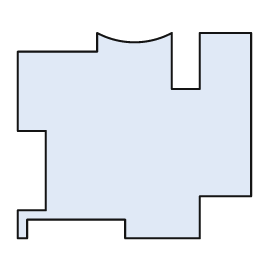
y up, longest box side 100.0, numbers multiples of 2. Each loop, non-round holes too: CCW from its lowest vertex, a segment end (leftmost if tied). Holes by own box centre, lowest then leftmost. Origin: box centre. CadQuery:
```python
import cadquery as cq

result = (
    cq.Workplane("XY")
    .moveTo(-50.0, -44.0)
    .lineTo(-46.0, -44.0)
    .lineTo(-46.0, -36.0)
    .lineTo(-4.0, -36.0)
    .lineTo(-4.0, -44.0)
    .lineTo(28.0, -44.0)
    .lineTo(28.0, -26.0)
    .lineTo(50.0, -26.0)
    .lineTo(50.0, 44.0)
    .lineTo(28.0, 44.0)
    .lineTo(28.0, 20.0)
    .lineTo(16.0, 20.0)
    .lineTo(16.0, 44.0)
    .threePointArc((0.0, 40.0), (-16.0, 44.0))
    .lineTo(-16.0, 36.0)
    .lineTo(-50.0, 36.0)
    .lineTo(-50.0, 2.0)
    .lineTo(-38.0, 2.0)
    .lineTo(-38.0, -32.0)
    .lineTo(-50.0, -32.0)
    .close()
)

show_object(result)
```